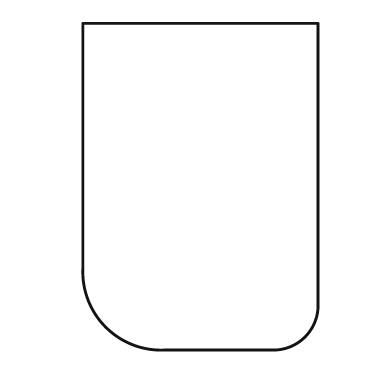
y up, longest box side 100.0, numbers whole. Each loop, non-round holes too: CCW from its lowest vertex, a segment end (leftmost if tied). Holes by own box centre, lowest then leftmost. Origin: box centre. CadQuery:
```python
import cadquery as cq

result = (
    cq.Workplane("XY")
    .moveTo(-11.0, -50.0)
    .lineTo(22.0, -50.0)
    .threePointArc((32.0, -46.0), (36.0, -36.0))
    .lineTo(36.0, 50.0)
    .lineTo(-36.0, 50.0)
    .lineTo(-36.0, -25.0)
    .threePointArc((-29.0, -43.0), (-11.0, -50.0))
    .close()
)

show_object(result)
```